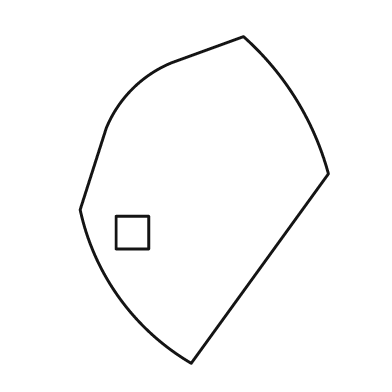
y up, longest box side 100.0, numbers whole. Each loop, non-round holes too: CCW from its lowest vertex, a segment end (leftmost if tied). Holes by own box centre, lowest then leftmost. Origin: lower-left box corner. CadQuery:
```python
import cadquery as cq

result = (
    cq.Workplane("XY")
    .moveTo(34.0, 0.0)
    .lineTo(76.0, 58.0)
    .threePointArc((66.0, 81.0), (50.0, 100.0))
    .lineTo(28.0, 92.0)
    .threePointArc((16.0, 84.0), (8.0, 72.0))
    .lineTo(0.0, 47.0)
    .threePointArc((12.0, 20.0), (34.0, 0.0))
    .close()
    .moveTo(11.0, 35.0)
    .lineTo(21.0, 35.0)
    .lineTo(21.0, 45.0)
    .lineTo(11.0, 45.0)
    .close()
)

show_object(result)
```